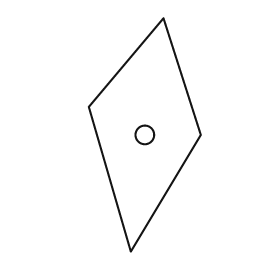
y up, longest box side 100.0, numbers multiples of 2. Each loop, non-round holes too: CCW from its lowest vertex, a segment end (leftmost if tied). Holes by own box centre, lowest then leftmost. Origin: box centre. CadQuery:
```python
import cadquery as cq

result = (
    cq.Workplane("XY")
    .moveTo(-6.0, -50.0)
    .lineTo(24.0, 0.0)
    .lineTo(8.0, 50.0)
    .lineTo(-24.0, 12.0)
    .close()
    .moveTo(0.0, 0.0)
    .circle(4.0)
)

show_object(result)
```